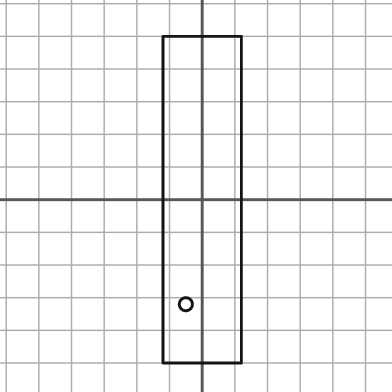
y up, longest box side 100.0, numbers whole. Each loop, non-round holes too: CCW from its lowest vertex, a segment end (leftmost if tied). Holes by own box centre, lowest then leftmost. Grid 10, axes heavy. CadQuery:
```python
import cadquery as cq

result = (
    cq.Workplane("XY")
    .moveTo(-12.0, -50.0)
    .lineTo(12.0, -50.0)
    .lineTo(12.0, 50.0)
    .lineTo(-12.0, 50.0)
    .close()
    .moveTo(-5.0, -32.0)
    .circle(2.0)
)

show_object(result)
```